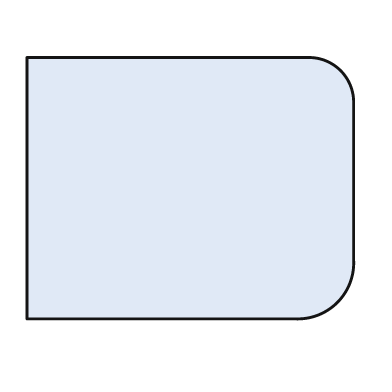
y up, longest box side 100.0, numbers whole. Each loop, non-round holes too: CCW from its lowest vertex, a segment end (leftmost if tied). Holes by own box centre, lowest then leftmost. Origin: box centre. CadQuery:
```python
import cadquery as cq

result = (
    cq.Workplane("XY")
    .moveTo(-50.0, -40.0)
    .lineTo(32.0, -40.0)
    .threePointArc((45.0, -35.0), (50.0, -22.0))
    .lineTo(50.0, 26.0)
    .threePointArc((46.0, 36.0), (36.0, 40.0))
    .lineTo(-50.0, 40.0)
    .close()
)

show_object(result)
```